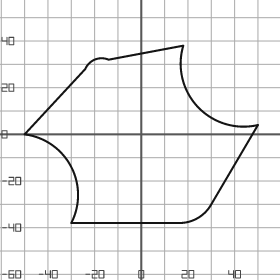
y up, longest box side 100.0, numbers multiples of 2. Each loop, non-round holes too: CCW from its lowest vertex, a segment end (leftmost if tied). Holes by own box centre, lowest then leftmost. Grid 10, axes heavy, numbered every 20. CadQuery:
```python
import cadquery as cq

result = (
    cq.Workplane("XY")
    .moveTo(-30.0, -38.0)
    .lineTo(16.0, -38.0)
    .threePointArc((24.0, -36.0), (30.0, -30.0))
    .lineTo(50.0, 4.0)
    .threePointArc((24.0, 12.0), (18.0, 38.0))
    .lineTo(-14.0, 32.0)
    .threePointArc((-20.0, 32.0), (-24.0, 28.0))
    .lineTo(-50.0, 0.0)
    .threePointArc((-30.0, -14.0), (-30.0, -38.0))
    .close()
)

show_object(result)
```